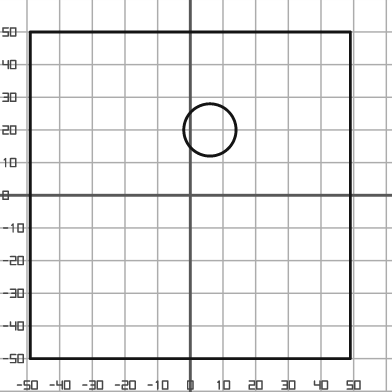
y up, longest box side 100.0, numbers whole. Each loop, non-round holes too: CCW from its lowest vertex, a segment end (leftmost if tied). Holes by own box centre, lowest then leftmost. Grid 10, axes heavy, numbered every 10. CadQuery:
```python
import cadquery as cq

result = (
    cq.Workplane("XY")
    .moveTo(-49.0, -50.0)
    .lineTo(49.0, -50.0)
    .lineTo(49.0, 50.0)
    .lineTo(-49.0, 50.0)
    .close()
    .moveTo(6.0, 20.0)
    .circle(8.0)
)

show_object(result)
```